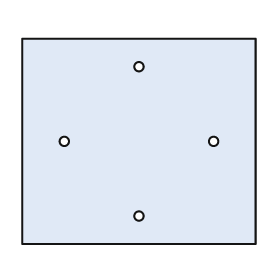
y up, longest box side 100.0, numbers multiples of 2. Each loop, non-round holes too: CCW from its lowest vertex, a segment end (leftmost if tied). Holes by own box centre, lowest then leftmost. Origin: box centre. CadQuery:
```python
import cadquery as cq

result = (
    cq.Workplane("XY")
    .moveTo(-50.0, -44.0)
    .lineTo(50.0, -44.0)
    .lineTo(50.0, 44.0)
    .lineTo(-50.0, 44.0)
    .close()
    .moveTo(0.0, -32.0)
    .circle(2.0)
    .moveTo(-32.0, 0.0)
    .circle(2.0)
    .moveTo(32.0, 0.0)
    .circle(2.0)
    .moveTo(0.0, 32.0)
    .circle(2.0)
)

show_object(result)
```